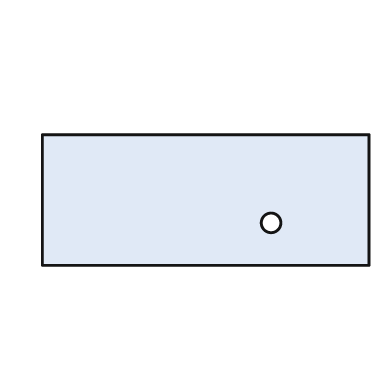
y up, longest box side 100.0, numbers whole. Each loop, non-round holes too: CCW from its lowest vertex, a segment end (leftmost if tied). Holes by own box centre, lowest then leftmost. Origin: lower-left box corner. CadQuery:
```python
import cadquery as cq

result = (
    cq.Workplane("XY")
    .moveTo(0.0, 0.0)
    .lineTo(100.0, 0.0)
    .lineTo(100.0, 40.0)
    .lineTo(0.0, 40.0)
    .close()
    .moveTo(70.0, 13.0)
    .circle(3.0)
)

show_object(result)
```